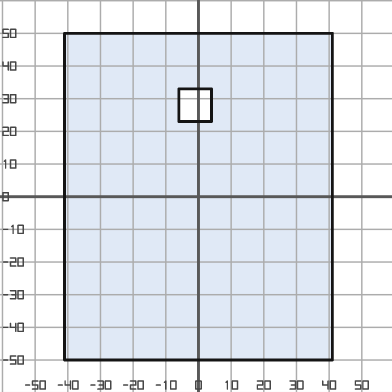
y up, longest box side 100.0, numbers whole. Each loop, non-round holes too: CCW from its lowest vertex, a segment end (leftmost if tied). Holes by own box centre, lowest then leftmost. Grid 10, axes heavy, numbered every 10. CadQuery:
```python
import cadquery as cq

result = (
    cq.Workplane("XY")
    .moveTo(-41.0, -50.0)
    .lineTo(41.0, -50.0)
    .lineTo(41.0, 50.0)
    .lineTo(-41.0, 50.0)
    .close()
    .moveTo(-6.0, 23.0)
    .lineTo(4.0, 23.0)
    .lineTo(4.0, 33.0)
    .lineTo(-6.0, 33.0)
    .close()
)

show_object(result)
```